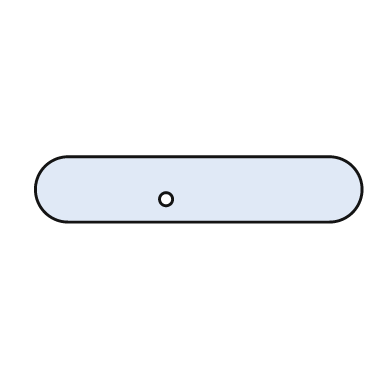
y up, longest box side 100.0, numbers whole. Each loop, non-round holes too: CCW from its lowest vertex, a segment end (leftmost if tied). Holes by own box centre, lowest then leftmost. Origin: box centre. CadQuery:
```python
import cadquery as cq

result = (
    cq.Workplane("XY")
    .moveTo(-40.0, -10.0)
    .lineTo(40.0, -10.0)
    .threePointArc((50.0, 0.0), (40.0, 10.0))
    .lineTo(-40.0, 10.0)
    .threePointArc((-50.0, 0.0), (-40.0, -10.0))
    .close()
    .moveTo(-10.0, -3.0)
    .circle(2.0)
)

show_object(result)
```